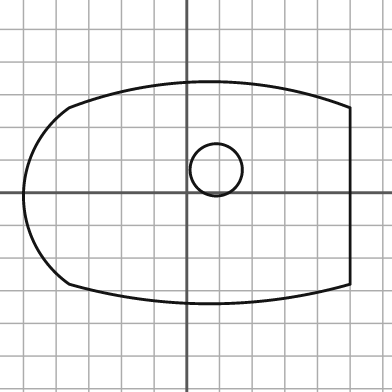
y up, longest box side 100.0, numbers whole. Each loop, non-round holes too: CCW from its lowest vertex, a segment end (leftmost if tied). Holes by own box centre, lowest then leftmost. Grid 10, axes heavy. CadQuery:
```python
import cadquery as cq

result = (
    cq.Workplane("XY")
    .moveTo(-36.0, -28.0)
    .threePointArc((7.0, -34.0), (50.0, -28.0))
    .lineTo(50.0, 26.0)
    .threePointArc((7.0, 34.0), (-36.0, 26.0))
    .threePointArc((-50.0, -1.0), (-36.0, -28.0))
    .close()
    .moveTo(9.0, 7.0)
    .circle(8.0)
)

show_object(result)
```